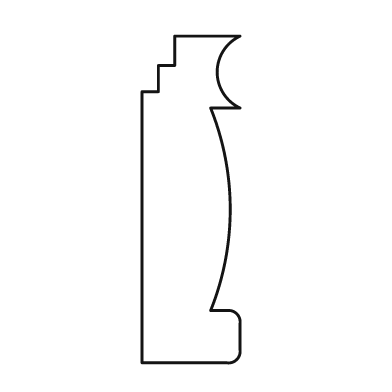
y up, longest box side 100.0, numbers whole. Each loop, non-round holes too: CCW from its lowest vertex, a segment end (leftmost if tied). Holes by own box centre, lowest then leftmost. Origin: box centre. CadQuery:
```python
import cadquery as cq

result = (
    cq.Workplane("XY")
    .moveTo(-15.0, -50.0)
    .lineTo(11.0, -50.0)
    .threePointArc((14.0, -49.0), (15.0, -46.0))
    .lineTo(15.0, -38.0)
    .threePointArc((14.0, -35.0), (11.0, -34.0))
    .lineTo(6.0, -34.0)
    .threePointArc((12.0, -3.0), (6.0, 28.0))
    .lineTo(15.0, 28.0)
    .threePointArc((8.0, 39.0), (15.0, 50.0))
    .lineTo(-5.0, 50.0)
    .lineTo(-5.0, 41.0)
    .lineTo(-10.0, 41.0)
    .lineTo(-10.0, 33.0)
    .lineTo(-15.0, 33.0)
    .close()
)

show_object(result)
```